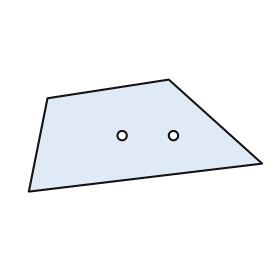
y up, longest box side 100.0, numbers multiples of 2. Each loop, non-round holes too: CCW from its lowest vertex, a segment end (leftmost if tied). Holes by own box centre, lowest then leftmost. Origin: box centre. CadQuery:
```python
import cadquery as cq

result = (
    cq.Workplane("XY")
    .moveTo(-50.0, -24.0)
    .lineTo(50.0, -12.0)
    .lineTo(10.0, 24.0)
    .lineTo(-42.0, 16.0)
    .close()
    .moveTo(-10.0, 0.0)
    .circle(2.0)
    .moveTo(12.0, 0.0)
    .circle(2.0)
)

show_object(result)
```